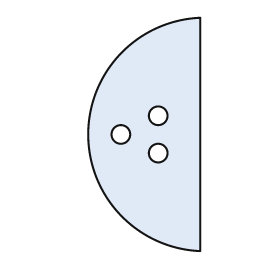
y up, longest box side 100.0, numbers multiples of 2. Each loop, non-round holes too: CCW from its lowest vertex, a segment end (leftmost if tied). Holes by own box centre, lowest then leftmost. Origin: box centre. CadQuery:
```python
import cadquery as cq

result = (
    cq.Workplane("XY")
    .moveTo(24.0, -50.0)
    .lineTo(24.0, 50.0)
    .threePointArc((-24.0, 0.0), (24.0, -50.0))
    .close()
    .moveTo(6.0, -8.0)
    .circle(4.0)
    .moveTo(-10.0, 0.0)
    .circle(4.0)
    .moveTo(6.0, 8.0)
    .circle(4.0)
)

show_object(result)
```